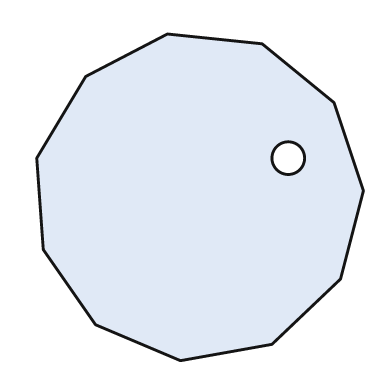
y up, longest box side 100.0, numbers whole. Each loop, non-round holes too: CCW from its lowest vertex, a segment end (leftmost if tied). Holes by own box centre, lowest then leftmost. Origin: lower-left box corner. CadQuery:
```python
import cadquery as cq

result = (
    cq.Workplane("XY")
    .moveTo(44.0, 0.0)
    .lineTo(72.0, 5.0)
    .lineTo(93.0, 25.0)
    .lineTo(100.0, 52.0)
    .lineTo(91.0, 79.0)
    .lineTo(69.0, 97.0)
    .lineTo(40.0, 100.0)
    .lineTo(15.0, 87.0)
    .lineTo(0.0, 62.0)
    .lineTo(2.0, 34.0)
    .lineTo(18.0, 11.0)
    .close()
    .moveTo(77.0, 62.0)
    .circle(5.0)
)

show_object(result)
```